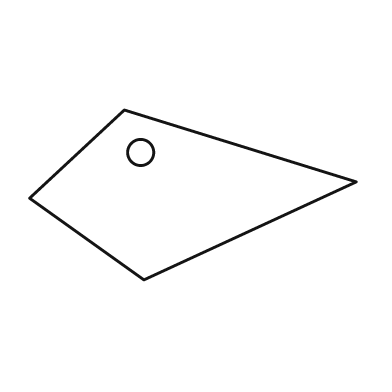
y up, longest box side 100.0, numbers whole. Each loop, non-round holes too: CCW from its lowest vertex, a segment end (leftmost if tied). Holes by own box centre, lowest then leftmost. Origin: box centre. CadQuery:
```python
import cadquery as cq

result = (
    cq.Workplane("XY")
    .moveTo(-15.0, -26.0)
    .lineTo(50.0, 4.0)
    .lineTo(-21.0, 26.0)
    .lineTo(-50.0, -1.0)
    .close()
    .moveTo(-16.0, 13.0)
    .circle(4.0)
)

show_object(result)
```